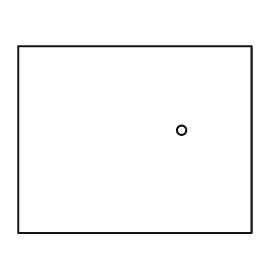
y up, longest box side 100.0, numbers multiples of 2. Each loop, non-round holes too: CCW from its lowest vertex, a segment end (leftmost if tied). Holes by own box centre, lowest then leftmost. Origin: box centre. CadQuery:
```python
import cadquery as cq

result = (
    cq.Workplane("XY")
    .moveTo(-50.0, -40.0)
    .lineTo(50.0, -40.0)
    .lineTo(50.0, 40.0)
    .lineTo(-50.0, 40.0)
    .close()
    .moveTo(20.0, 4.0)
    .circle(2.0)
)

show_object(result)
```